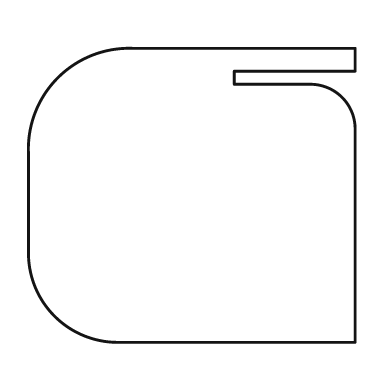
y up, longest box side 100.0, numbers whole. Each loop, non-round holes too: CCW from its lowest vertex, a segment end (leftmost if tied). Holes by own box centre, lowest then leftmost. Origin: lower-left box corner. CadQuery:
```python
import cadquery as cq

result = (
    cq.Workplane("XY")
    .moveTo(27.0, 0.0)
    .lineTo(100.0, 0.0)
    .lineTo(100.0, 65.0)
    .threePointArc((96.0, 75.0), (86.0, 79.0))
    .lineTo(63.0, 79.0)
    .lineTo(63.0, 83.0)
    .lineTo(100.0, 83.0)
    .lineTo(100.0, 90.0)
    .lineTo(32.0, 90.0)
    .threePointArc((9.0, 81.0), (0.0, 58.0))
    .lineTo(0.0, 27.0)
    .threePointArc((8.0, 8.0), (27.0, 0.0))
    .close()
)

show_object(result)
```